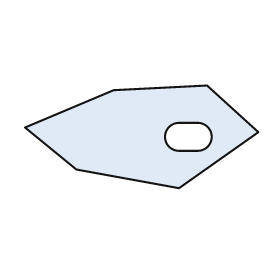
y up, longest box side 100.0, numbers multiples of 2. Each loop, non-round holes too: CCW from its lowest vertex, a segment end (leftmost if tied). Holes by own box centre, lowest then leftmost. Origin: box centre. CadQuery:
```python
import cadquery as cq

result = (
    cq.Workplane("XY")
    .moveTo(16.0, -22.0)
    .lineTo(50.0, 2.0)
    .lineTo(28.0, 22.0)
    .lineTo(-12.0, 20.0)
    .lineTo(-50.0, 4.0)
    .lineTo(-28.0, -14.0)
    .close()
    .moveTo(16.0, -6.0)
    .lineTo(24.0, -6.0)
    .threePointArc((30.0, 0.0), (24.0, 6.0))
    .lineTo(16.0, 6.0)
    .threePointArc((10.0, 0.0), (16.0, -6.0))
    .close()
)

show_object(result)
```